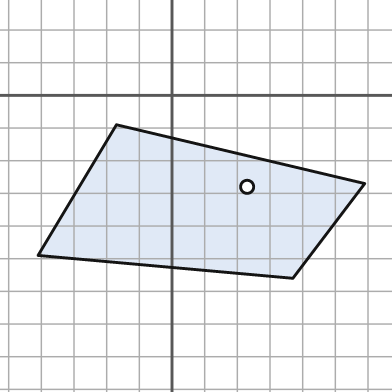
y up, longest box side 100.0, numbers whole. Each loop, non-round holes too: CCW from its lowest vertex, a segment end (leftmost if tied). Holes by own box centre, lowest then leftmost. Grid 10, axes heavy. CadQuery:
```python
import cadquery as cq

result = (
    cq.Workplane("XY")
    .moveTo(37.0, -56.0)
    .lineTo(59.0, -27.0)
    .lineTo(-17.0, -9.0)
    .lineTo(-41.0, -49.0)
    .close()
    .moveTo(23.0, -28.0)
    .circle(2.0)
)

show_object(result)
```